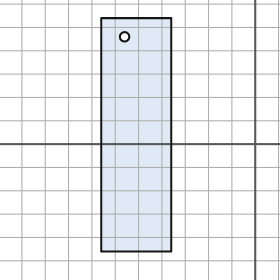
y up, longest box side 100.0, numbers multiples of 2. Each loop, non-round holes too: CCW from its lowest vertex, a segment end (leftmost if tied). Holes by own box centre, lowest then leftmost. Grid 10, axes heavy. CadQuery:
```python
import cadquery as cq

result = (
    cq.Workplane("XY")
    .moveTo(-66.0, -46.0)
    .lineTo(-36.0, -46.0)
    .lineTo(-36.0, 54.0)
    .lineTo(-66.0, 54.0)
    .close()
    .moveTo(-56.0, 46.0)
    .circle(2.0)
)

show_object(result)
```